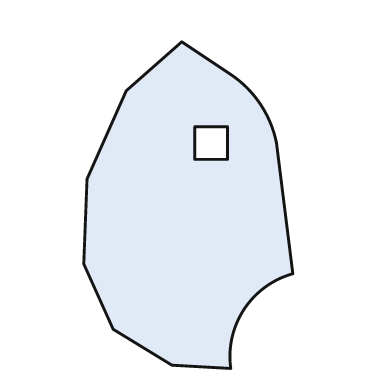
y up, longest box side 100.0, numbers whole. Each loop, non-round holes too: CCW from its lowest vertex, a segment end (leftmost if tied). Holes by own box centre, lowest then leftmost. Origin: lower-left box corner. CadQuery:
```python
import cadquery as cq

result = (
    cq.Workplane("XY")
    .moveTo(45.0, 0.0)
    .threePointArc((49.0, 18.0), (64.0, 29.0))
    .lineTo(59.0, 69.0)
    .threePointArc((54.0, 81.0), (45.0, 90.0))
    .lineTo(30.0, 100.0)
    .lineTo(13.0, 85.0)
    .lineTo(1.0, 58.0)
    .lineTo(0.0, 32.0)
    .lineTo(9.0, 12.0)
    .lineTo(27.0, 1.0)
    .close()
    .moveTo(34.0, 64.0)
    .lineTo(44.0, 64.0)
    .lineTo(44.0, 74.0)
    .lineTo(34.0, 74.0)
    .close()
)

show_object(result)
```